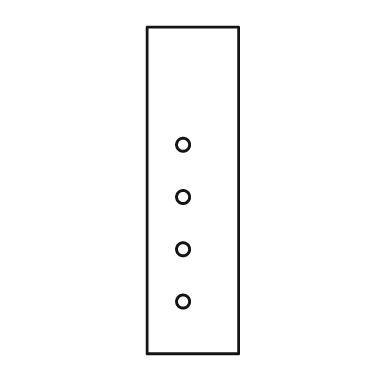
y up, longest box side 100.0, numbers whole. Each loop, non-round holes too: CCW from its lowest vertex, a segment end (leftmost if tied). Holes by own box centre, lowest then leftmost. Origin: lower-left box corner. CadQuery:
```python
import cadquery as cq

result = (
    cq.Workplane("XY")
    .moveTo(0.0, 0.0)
    .lineTo(28.0, 0.0)
    .lineTo(28.0, 100.0)
    .lineTo(0.0, 100.0)
    .close()
    .moveTo(11.0, 16.0)
    .circle(2.0)
    .moveTo(11.0, 32.0)
    .circle(2.0)
    .moveTo(11.0, 48.0)
    .circle(2.0)
    .moveTo(11.0, 64.0)
    .circle(2.0)
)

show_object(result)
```